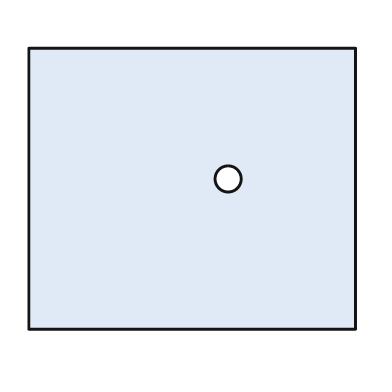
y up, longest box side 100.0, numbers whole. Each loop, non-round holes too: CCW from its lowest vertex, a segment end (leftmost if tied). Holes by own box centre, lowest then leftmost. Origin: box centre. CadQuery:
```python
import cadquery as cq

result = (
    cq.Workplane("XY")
    .moveTo(-50.0, -43.0)
    .lineTo(50.0, -43.0)
    .lineTo(50.0, 43.0)
    .lineTo(-50.0, 43.0)
    .close()
    .moveTo(11.0, 3.0)
    .circle(4.0)
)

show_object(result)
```